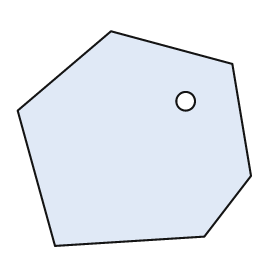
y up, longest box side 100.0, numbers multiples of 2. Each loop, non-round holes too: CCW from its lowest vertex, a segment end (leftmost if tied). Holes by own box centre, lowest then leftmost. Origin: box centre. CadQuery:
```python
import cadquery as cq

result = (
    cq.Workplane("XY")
    .moveTo(-34.0, -46.0)
    .lineTo(30.0, -42.0)
    .lineTo(50.0, -16.0)
    .lineTo(42.0, 32.0)
    .lineTo(-10.0, 46.0)
    .lineTo(-50.0, 12.0)
    .close()
    .moveTo(22.0, 16.0)
    .circle(4.0)
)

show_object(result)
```